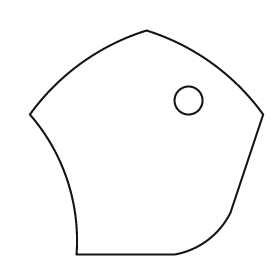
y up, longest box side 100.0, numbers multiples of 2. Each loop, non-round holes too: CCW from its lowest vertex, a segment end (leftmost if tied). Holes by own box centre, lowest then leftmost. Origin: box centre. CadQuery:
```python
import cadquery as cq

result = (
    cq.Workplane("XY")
    .moveTo(-30.0, -48.0)
    .lineTo(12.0, -48.0)
    .threePointArc((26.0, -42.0), (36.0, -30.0))
    .lineTo(50.0, 12.0)
    .threePointArc((28.0, 34.0), (0.0, 48.0))
    .threePointArc((-28.0, 34.0), (-50.0, 12.0))
    .threePointArc((-34.0, -16.0), (-30.0, -48.0))
    .close()
    .moveTo(18.0, 18.0)
    .circle(6.0)
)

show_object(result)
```